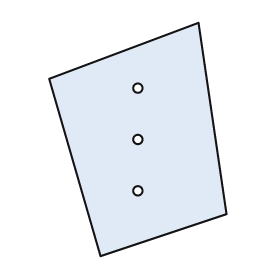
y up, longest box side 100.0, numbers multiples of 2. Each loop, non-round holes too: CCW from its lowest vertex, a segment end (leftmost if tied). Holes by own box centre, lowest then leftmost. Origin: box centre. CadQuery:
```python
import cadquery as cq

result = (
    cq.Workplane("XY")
    .moveTo(-16.0, -50.0)
    .lineTo(38.0, -32.0)
    .lineTo(26.0, 50.0)
    .lineTo(-38.0, 26.0)
    .close()
    .moveTo(0.0, -22.0)
    .circle(2.0)
    .moveTo(0.0, 0.0)
    .circle(2.0)
    .moveTo(0.0, 22.0)
    .circle(2.0)
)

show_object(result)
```